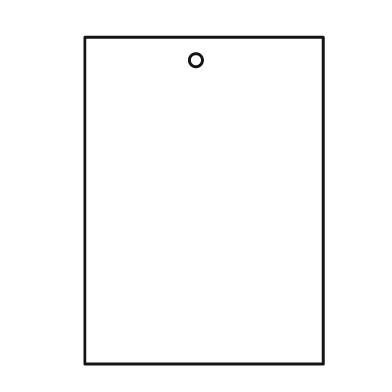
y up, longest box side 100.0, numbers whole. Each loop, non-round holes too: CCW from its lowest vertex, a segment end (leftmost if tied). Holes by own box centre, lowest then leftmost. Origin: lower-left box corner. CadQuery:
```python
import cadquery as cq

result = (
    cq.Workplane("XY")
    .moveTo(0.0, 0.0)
    .lineTo(73.0, 0.0)
    .lineTo(73.0, 100.0)
    .lineTo(0.0, 100.0)
    .close()
    .moveTo(34.0, 93.0)
    .circle(2.0)
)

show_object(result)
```